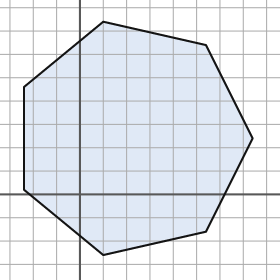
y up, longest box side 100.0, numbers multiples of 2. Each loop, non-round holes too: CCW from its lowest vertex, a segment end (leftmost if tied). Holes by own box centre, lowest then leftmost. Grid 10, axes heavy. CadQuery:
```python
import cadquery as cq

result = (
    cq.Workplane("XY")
    .moveTo(10.0, -26.0)
    .lineTo(54.0, -16.0)
    .lineTo(74.0, 24.0)
    .lineTo(54.0, 64.0)
    .lineTo(10.0, 74.0)
    .lineTo(-24.0, 46.0)
    .lineTo(-24.0, 2.0)
    .close()
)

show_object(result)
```